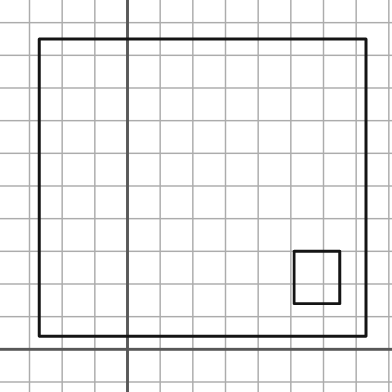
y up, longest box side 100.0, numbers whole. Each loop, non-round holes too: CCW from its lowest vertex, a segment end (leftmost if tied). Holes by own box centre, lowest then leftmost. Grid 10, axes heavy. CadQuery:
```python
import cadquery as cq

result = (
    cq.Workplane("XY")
    .moveTo(-27.0, 4.0)
    .lineTo(73.0, 4.0)
    .lineTo(73.0, 95.0)
    .lineTo(-27.0, 95.0)
    .close()
    .moveTo(51.0, 14.0)
    .lineTo(65.0, 14.0)
    .lineTo(65.0, 30.0)
    .lineTo(51.0, 30.0)
    .close()
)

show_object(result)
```